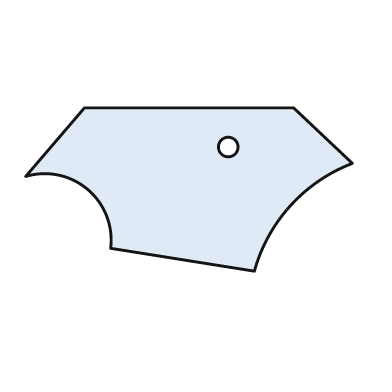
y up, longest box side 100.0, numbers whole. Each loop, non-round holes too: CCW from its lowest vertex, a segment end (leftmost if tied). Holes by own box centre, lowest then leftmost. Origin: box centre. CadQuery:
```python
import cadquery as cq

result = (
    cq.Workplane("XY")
    .moveTo(20.0, -25.0)
    .threePointArc((31.0, -5.0), (50.0, 8.0))
    .lineTo(32.0, 25.0)
    .lineTo(-32.0, 25.0)
    .lineTo(-50.0, 4.0)
    .threePointArc((-31.0, 0.0), (-24.0, -18.0))
    .close()
    .moveTo(12.0, 13.0)
    .circle(3.0)
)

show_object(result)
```